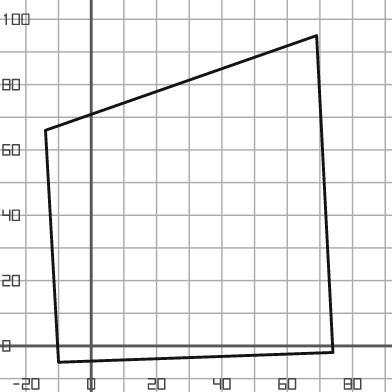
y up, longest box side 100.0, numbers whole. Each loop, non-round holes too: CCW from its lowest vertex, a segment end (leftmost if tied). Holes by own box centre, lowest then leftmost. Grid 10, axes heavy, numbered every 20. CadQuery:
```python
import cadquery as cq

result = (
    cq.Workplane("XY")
    .moveTo(-10.0, -5.0)
    .lineTo(74.0, -2.0)
    .lineTo(69.0, 95.0)
    .lineTo(-14.0, 66.0)
    .close()
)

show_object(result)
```